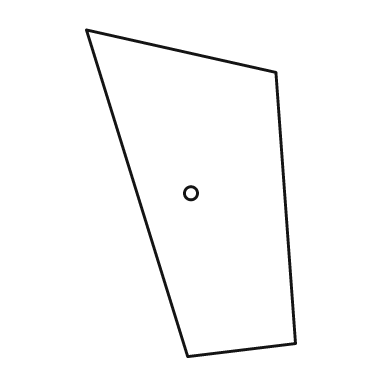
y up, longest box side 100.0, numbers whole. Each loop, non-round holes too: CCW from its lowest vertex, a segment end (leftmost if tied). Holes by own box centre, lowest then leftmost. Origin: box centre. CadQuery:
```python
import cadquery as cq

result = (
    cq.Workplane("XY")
    .moveTo(-1.0, -50.0)
    .lineTo(32.0, -46.0)
    .lineTo(26.0, 37.0)
    .lineTo(-32.0, 50.0)
    .close()
    .moveTo(0.0, 0.0)
    .circle(2.0)
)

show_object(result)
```